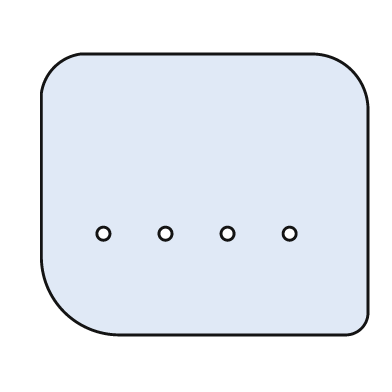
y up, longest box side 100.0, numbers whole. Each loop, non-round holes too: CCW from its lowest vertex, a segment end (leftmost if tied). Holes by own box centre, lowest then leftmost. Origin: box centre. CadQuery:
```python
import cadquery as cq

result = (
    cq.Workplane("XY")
    .moveTo(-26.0, -43.0)
    .lineTo(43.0, -43.0)
    .threePointArc((48.0, -41.0), (50.0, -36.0))
    .lineTo(50.0, 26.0)
    .threePointArc((45.0, 38.0), (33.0, 43.0))
    .lineTo(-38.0, 43.0)
    .threePointArc((-46.0, 39.0), (-50.0, 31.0))
    .lineTo(-50.0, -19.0)
    .threePointArc((-43.0, -36.0), (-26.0, -43.0))
    .close()
    .moveTo(-31.0, -12.0)
    .circle(2.0)
    .moveTo(-12.0, -12.0)
    .circle(2.0)
    .moveTo(7.0, -12.0)
    .circle(2.0)
    .moveTo(26.0, -12.0)
    .circle(2.0)
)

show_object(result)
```